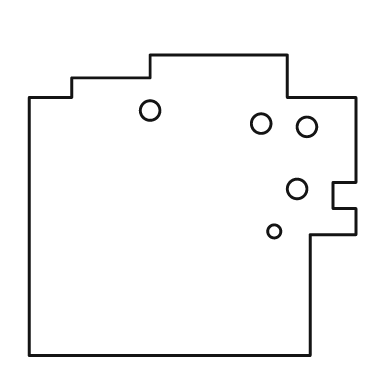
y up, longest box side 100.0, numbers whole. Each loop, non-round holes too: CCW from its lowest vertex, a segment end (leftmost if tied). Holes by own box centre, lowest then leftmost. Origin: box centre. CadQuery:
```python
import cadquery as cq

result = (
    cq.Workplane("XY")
    .moveTo(-50.0, -46.0)
    .lineTo(36.0, -46.0)
    .lineTo(36.0, -9.0)
    .lineTo(50.0, -9.0)
    .lineTo(50.0, -1.0)
    .lineTo(43.0, -1.0)
    .lineTo(43.0, 7.0)
    .lineTo(50.0, 7.0)
    .lineTo(50.0, 33.0)
    .lineTo(29.0, 33.0)
    .lineTo(29.0, 46.0)
    .lineTo(-13.0, 46.0)
    .lineTo(-13.0, 39.0)
    .lineTo(-37.0, 39.0)
    .lineTo(-37.0, 33.0)
    .lineTo(-50.0, 33.0)
    .close()
    .moveTo(25.0, -8.0)
    .circle(2.0)
    .moveTo(32.0, 5.0)
    .circle(3.0)
    .moveTo(35.0, 24.0)
    .circle(3.0)
    .moveTo(21.0, 25.0)
    .circle(3.0)
    .moveTo(-13.0, 29.0)
    .circle(3.0)
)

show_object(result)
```